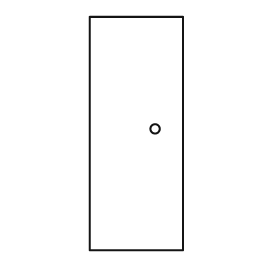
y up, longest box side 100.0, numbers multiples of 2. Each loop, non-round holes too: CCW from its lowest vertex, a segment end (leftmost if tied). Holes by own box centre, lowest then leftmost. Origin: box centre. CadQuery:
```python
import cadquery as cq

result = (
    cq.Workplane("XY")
    .moveTo(-20.0, -50.0)
    .lineTo(20.0, -50.0)
    .lineTo(20.0, 50.0)
    .lineTo(-20.0, 50.0)
    .close()
    .moveTo(8.0, 2.0)
    .circle(2.0)
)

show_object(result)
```